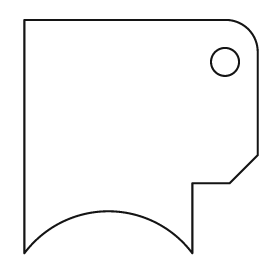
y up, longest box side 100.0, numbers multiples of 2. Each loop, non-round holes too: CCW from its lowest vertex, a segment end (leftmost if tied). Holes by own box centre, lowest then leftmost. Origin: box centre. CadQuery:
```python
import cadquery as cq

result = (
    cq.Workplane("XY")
    .moveTo(-50.0, -50.0)
    .threePointArc((-14.0, -32.0), (22.0, -50.0))
    .lineTo(22.0, -20.0)
    .lineTo(38.0, -20.0)
    .lineTo(50.0, -8.0)
    .lineTo(50.0, 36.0)
    .threePointArc((46.0, 46.0), (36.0, 50.0))
    .lineTo(-50.0, 50.0)
    .close()
    .moveTo(36.0, 32.0)
    .circle(6.0)
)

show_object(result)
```